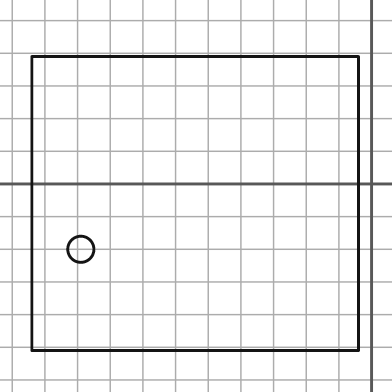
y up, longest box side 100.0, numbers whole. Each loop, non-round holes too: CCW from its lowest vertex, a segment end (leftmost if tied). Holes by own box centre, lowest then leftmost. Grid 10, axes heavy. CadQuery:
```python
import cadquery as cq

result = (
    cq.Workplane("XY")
    .moveTo(-104.0, -51.0)
    .lineTo(-4.0, -51.0)
    .lineTo(-4.0, 39.0)
    .lineTo(-104.0, 39.0)
    .close()
    .moveTo(-89.0, -20.0)
    .circle(4.0)
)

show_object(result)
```